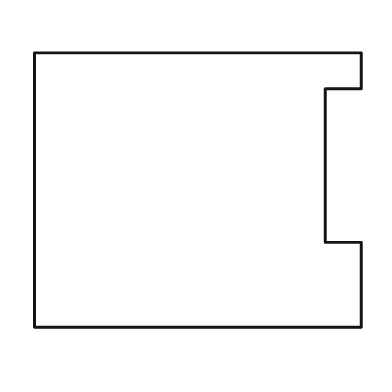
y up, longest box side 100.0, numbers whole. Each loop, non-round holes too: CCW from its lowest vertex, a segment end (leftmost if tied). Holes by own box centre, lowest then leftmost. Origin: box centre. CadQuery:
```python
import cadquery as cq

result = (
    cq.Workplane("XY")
    .moveTo(-50.0, -42.0)
    .lineTo(50.0, -42.0)
    .lineTo(50.0, -16.0)
    .lineTo(39.0, -16.0)
    .lineTo(39.0, 31.0)
    .lineTo(50.0, 31.0)
    .lineTo(50.0, 42.0)
    .lineTo(-50.0, 42.0)
    .close()
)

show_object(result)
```